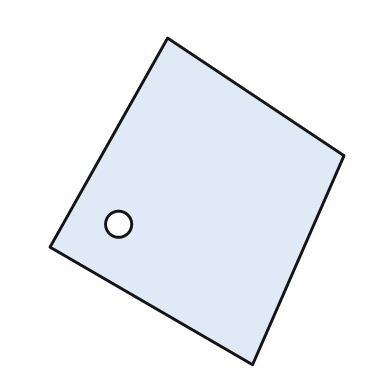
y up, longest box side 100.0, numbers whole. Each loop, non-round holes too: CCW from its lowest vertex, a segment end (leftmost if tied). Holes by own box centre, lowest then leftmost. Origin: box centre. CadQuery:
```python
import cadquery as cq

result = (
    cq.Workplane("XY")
    .moveTo(17.0, -50.0)
    .lineTo(45.0, 14.0)
    .lineTo(-9.0, 50.0)
    .lineTo(-45.0, -14.0)
    .close()
    .moveTo(-24.0, -7.0)
    .circle(4.0)
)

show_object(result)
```